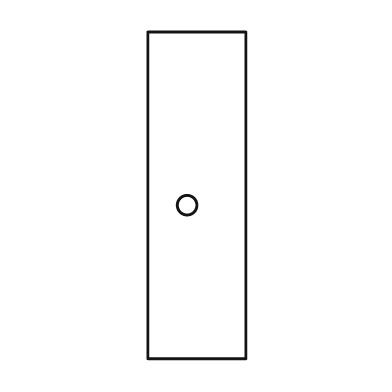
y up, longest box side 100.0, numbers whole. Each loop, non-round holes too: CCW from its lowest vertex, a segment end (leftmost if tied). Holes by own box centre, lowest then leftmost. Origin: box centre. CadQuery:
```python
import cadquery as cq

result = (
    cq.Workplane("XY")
    .moveTo(-15.0, -50.0)
    .lineTo(15.0, -50.0)
    .lineTo(15.0, 50.0)
    .lineTo(-15.0, 50.0)
    .close()
    .moveTo(-3.0, -3.0)
    .circle(3.0)
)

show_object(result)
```